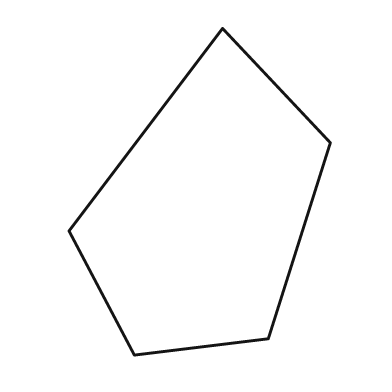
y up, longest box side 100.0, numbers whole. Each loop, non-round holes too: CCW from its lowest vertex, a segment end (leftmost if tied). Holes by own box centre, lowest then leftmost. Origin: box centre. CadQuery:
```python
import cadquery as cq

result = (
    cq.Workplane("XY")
    .moveTo(-20.0, -50.0)
    .lineTo(21.0, -45.0)
    .lineTo(40.0, 15.0)
    .lineTo(7.0, 50.0)
    .lineTo(-40.0, -12.0)
    .close()
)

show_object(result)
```